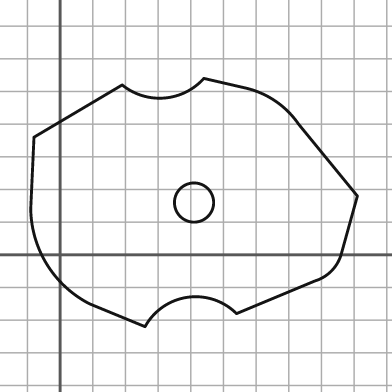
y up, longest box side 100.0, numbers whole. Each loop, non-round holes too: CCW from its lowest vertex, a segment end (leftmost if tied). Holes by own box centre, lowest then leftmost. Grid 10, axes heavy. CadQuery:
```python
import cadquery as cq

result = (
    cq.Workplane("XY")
    .moveTo(26.0, -22.0)
    .threePointArc((39.0, -13.0), (54.0, -18.0))
    .lineTo(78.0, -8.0)
    .threePointArc((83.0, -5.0), (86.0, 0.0))
    .lineTo(91.0, 18.0)
    .lineTo(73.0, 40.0)
    .threePointArc((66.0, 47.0), (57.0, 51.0))
    .lineTo(44.0, 54.0)
    .threePointArc((32.0, 48.0), (19.0, 52.0))
    .lineTo(-8.0, 36.0)
    .lineTo(-9.0, 14.0)
    .threePointArc((-4.0, -3.0), (9.0, -15.0))
    .close()
    .moveTo(41.0, 16.0)
    .circle(6.0)
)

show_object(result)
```